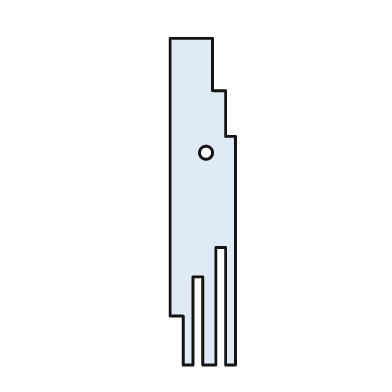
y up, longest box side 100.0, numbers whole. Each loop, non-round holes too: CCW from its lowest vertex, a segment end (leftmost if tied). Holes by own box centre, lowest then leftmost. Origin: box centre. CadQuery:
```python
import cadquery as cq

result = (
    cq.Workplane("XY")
    .moveTo(-6.0, -50.0)
    .lineTo(-3.0, -50.0)
    .lineTo(-3.0, -23.0)
    .lineTo(0.0, -23.0)
    .lineTo(0.0, -50.0)
    .lineTo(4.0, -50.0)
    .lineTo(4.0, -14.0)
    .lineTo(7.0, -14.0)
    .lineTo(7.0, -50.0)
    .lineTo(10.0, -50.0)
    .lineTo(10.0, 20.0)
    .lineTo(7.0, 20.0)
    .lineTo(7.0, 34.0)
    .lineTo(3.0, 34.0)
    .lineTo(3.0, 50.0)
    .lineTo(-10.0, 50.0)
    .lineTo(-10.0, -35.0)
    .lineTo(-6.0, -35.0)
    .close()
    .moveTo(1.0, 15.0)
    .circle(2.0)
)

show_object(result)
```